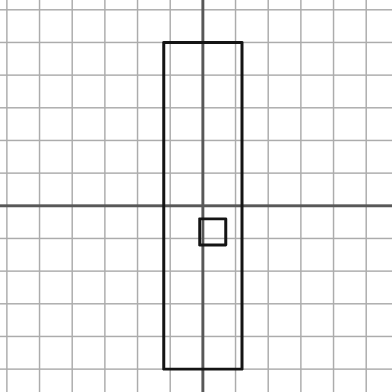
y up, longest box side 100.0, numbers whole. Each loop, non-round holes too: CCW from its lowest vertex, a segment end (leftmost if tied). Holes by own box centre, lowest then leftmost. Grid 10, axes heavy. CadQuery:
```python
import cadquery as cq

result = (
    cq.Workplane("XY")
    .moveTo(-12.0, -50.0)
    .lineTo(12.0, -50.0)
    .lineTo(12.0, 50.0)
    .lineTo(-12.0, 50.0)
    .close()
    .moveTo(-1.0, -12.0)
    .lineTo(7.0, -12.0)
    .lineTo(7.0, -4.0)
    .lineTo(-1.0, -4.0)
    .close()
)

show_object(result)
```